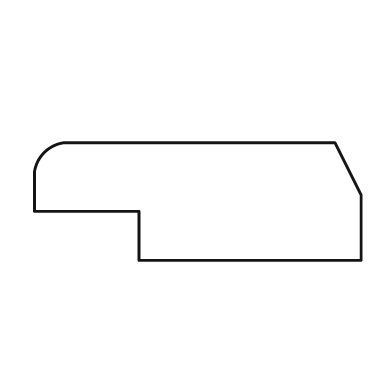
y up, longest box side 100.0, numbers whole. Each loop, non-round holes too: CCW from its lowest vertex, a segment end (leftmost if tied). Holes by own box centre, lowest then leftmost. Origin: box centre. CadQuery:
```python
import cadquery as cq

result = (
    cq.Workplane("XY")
    .moveTo(-18.0, -18.0)
    .lineTo(50.0, -18.0)
    .lineTo(50.0, 2.0)
    .lineTo(42.0, 18.0)
    .lineTo(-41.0, 18.0)
    .threePointArc((-47.0, 15.0), (-50.0, 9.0))
    .lineTo(-50.0, -3.0)
    .lineTo(-18.0, -3.0)
    .close()
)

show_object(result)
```